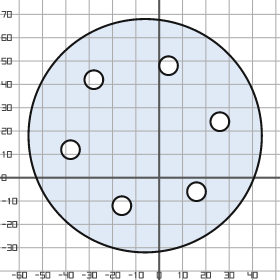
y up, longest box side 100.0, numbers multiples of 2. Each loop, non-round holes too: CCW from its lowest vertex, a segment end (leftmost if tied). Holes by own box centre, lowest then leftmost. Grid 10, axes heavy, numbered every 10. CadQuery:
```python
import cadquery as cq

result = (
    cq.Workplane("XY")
    .moveTo(-6.0, 18.0)
    .circle(50.0)
    .moveTo(-16.0, -12.0)
    .circle(4.0)
    .moveTo(16.0, -6.0)
    .circle(4.0)
    .moveTo(-38.0, 12.0)
    .circle(4.0)
    .moveTo(26.0, 24.0)
    .circle(4.0)
    .moveTo(-28.0, 42.0)
    .circle(4.0)
    .moveTo(4.0, 48.0)
    .circle(4.0)
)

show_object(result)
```